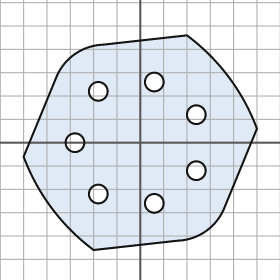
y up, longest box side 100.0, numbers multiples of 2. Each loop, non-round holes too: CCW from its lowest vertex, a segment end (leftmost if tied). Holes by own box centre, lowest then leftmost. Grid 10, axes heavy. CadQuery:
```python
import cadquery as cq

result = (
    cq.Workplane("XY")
    .moveTo(-20.0, -46.0)
    .lineTo(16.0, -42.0)
    .threePointArc((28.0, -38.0), (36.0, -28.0))
    .lineTo(50.0, 6.0)
    .threePointArc((38.0, 28.0), (20.0, 46.0))
    .lineTo(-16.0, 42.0)
    .threePointArc((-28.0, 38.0), (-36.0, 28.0))
    .lineTo(-50.0, -6.0)
    .threePointArc((-38.0, -28.0), (-20.0, -46.0))
    .close()
    .moveTo(6.0, -26.0)
    .circle(4.0)
    .moveTo(-18.0, -22.0)
    .circle(4.0)
    .moveTo(24.0, -12.0)
    .circle(4.0)
    .moveTo(-28.0, 0.0)
    .circle(4.0)
    .moveTo(24.0, 12.0)
    .circle(4.0)
    .moveTo(-18.0, 22.0)
    .circle(4.0)
    .moveTo(6.0, 26.0)
    .circle(4.0)
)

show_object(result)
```